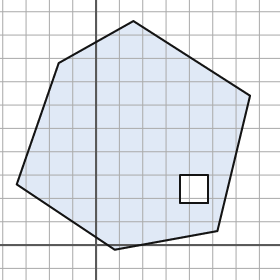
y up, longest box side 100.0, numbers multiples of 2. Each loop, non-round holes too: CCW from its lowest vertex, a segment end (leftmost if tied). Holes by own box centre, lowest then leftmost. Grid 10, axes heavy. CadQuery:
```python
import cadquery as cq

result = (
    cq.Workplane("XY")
    .moveTo(8.0, -2.0)
    .lineTo(52.0, 6.0)
    .lineTo(66.0, 64.0)
    .lineTo(16.0, 96.0)
    .lineTo(-16.0, 78.0)
    .lineTo(-34.0, 26.0)
    .close()
    .moveTo(36.0, 18.0)
    .lineTo(48.0, 18.0)
    .lineTo(48.0, 30.0)
    .lineTo(36.0, 30.0)
    .close()
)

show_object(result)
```